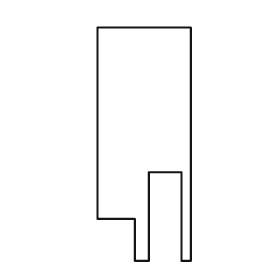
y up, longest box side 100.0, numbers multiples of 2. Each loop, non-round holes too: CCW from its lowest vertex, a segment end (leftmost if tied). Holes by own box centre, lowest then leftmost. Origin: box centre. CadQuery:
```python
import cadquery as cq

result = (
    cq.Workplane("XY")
    .moveTo(-4.0, -50.0)
    .lineTo(2.0, -50.0)
    .lineTo(2.0, -12.0)
    .lineTo(16.0, -12.0)
    .lineTo(16.0, -50.0)
    .lineTo(20.0, -50.0)
    .lineTo(20.0, 50.0)
    .lineTo(-20.0, 50.0)
    .lineTo(-20.0, -32.0)
    .lineTo(-4.0, -32.0)
    .close()
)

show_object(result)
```